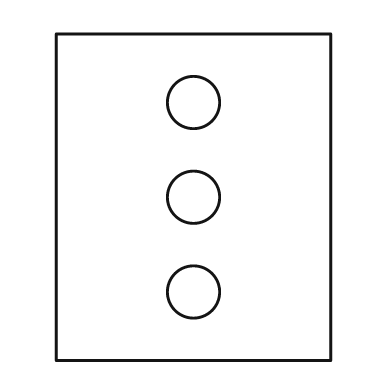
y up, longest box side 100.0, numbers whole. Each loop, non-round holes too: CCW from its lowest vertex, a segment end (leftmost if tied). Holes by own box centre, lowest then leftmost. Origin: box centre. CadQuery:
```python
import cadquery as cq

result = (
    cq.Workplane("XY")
    .moveTo(-42.0, -50.0)
    .lineTo(42.0, -50.0)
    .lineTo(42.0, 50.0)
    .lineTo(-42.0, 50.0)
    .close()
    .moveTo(0.0, -29.0)
    .circle(8.0)
    .moveTo(0.0, 0.0)
    .circle(8.0)
    .moveTo(0.0, 29.0)
    .circle(8.0)
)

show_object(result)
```